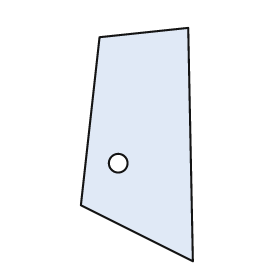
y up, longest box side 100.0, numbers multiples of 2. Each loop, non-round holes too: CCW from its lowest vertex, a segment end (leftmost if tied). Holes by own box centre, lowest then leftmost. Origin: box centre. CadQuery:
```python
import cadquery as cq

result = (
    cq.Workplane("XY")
    .moveTo(24.0, -50.0)
    .lineTo(22.0, 50.0)
    .lineTo(-16.0, 46.0)
    .lineTo(-24.0, -26.0)
    .close()
    .moveTo(-8.0, -8.0)
    .circle(4.0)
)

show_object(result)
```